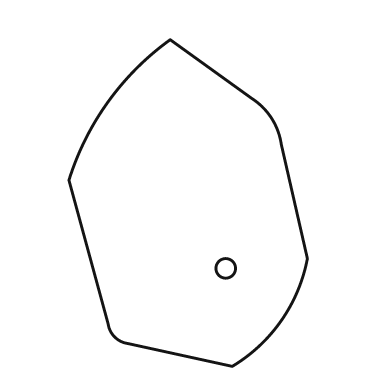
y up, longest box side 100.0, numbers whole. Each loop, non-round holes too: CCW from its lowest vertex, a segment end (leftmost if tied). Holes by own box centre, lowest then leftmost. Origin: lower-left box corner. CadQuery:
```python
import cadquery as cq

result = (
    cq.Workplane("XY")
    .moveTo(50.0, 0.0)
    .threePointArc((65.0, 14.0), (73.0, 33.0))
    .lineTo(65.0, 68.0)
    .threePointArc((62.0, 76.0), (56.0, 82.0))
    .lineTo(31.0, 100.0)
    .threePointArc((12.0, 81.0), (0.0, 57.0))
    .lineTo(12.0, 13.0)
    .threePointArc((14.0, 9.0), (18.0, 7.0))
    .close()
    .moveTo(48.0, 30.0)
    .circle(3.0)
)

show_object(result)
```